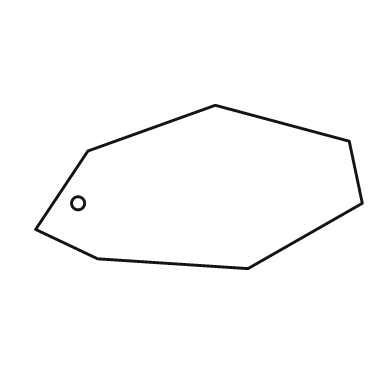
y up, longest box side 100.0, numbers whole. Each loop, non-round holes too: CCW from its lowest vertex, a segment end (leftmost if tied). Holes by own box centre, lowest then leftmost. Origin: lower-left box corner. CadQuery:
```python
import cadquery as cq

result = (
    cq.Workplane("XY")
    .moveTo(65.0, 0.0)
    .lineTo(100.0, 20.0)
    .lineTo(96.0, 39.0)
    .lineTo(55.0, 50.0)
    .lineTo(16.0, 36.0)
    .lineTo(0.0, 12.0)
    .lineTo(19.0, 3.0)
    .close()
    .moveTo(13.0, 20.0)
    .circle(2.0)
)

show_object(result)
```